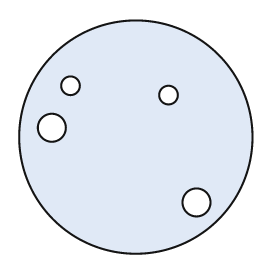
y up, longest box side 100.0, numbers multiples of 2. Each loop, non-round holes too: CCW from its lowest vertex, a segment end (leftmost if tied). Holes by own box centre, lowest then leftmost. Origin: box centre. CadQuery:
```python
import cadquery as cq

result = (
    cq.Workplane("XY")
    .moveTo(0.0, 0.0)
    .circle(50.0)
    .moveTo(26.0, -28.0)
    .circle(6.0)
    .moveTo(-36.0, 4.0)
    .circle(6.0)
    .moveTo(14.0, 18.0)
    .circle(4.0)
    .moveTo(-28.0, 22.0)
    .circle(4.0)
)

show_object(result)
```